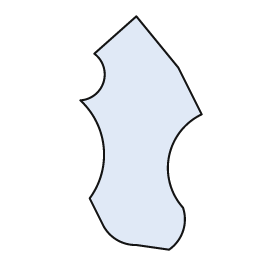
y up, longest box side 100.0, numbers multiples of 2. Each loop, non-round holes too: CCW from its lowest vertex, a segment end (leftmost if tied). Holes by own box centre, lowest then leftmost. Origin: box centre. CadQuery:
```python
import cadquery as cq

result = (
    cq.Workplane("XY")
    .moveTo(12.0, -50.0)
    .threePointArc((18.0, -42.0), (18.0, -32.0))
    .threePointArc((12.0, -10.0), (26.0, 8.0))
    .lineTo(16.0, 28.0)
    .lineTo(-2.0, 50.0)
    .lineTo(-20.0, 34.0)
    .threePointArc((-16.0, 22.0), (-26.0, 14.0))
    .threePointArc((-16.0, -6.0), (-22.0, -28.0))
    .lineTo(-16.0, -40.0)
    .threePointArc((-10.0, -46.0), (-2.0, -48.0))
    .close()
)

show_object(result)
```